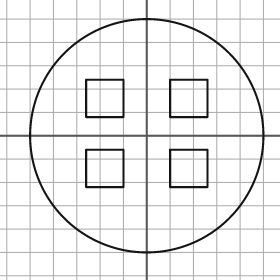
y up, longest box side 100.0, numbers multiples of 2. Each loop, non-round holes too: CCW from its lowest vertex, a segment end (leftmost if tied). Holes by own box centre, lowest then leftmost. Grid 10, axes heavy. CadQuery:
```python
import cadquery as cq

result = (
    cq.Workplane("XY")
    .moveTo(0.0, 0.0)
    .circle(50.0)
    .moveTo(-26.0, -22.0)
    .lineTo(-10.0, -22.0)
    .lineTo(-10.0, -6.0)
    .lineTo(-26.0, -6.0)
    .close()
    .moveTo(10.0, -22.0)
    .lineTo(26.0, -22.0)
    .lineTo(26.0, -6.0)
    .lineTo(10.0, -6.0)
    .close()
    .moveTo(-26.0, 8.0)
    .lineTo(-10.0, 8.0)
    .lineTo(-10.0, 24.0)
    .lineTo(-26.0, 24.0)
    .close()
    .moveTo(10.0, 8.0)
    .lineTo(26.0, 8.0)
    .lineTo(26.0, 24.0)
    .lineTo(10.0, 24.0)
    .close()
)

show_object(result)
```